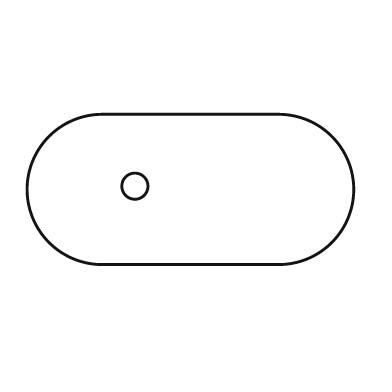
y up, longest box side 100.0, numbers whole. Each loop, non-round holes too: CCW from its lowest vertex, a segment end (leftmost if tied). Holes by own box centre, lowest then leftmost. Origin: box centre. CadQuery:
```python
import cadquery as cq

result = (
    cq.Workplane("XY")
    .moveTo(-27.0, -23.0)
    .lineTo(27.0, -23.0)
    .threePointArc((50.0, 0.0), (27.0, 23.0))
    .lineTo(-27.0, 23.0)
    .threePointArc((-50.0, 0.0), (-27.0, -23.0))
    .close()
    .moveTo(-17.0, 1.0)
    .circle(4.0)
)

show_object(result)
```